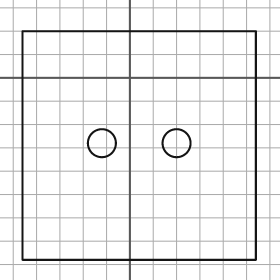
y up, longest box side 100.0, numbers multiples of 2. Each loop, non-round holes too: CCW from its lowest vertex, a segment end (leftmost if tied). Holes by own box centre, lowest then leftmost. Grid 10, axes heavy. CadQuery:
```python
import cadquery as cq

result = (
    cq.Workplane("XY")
    .moveTo(-46.0, -78.0)
    .lineTo(54.0, -78.0)
    .lineTo(54.0, 20.0)
    .lineTo(-46.0, 20.0)
    .close()
    .moveTo(-12.0, -28.0)
    .circle(6.0)
    .moveTo(20.0, -28.0)
    .circle(6.0)
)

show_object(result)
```